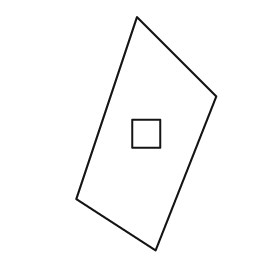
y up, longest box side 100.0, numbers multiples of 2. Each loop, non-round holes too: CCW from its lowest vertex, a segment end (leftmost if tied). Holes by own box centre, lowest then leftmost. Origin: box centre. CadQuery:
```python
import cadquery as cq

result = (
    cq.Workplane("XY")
    .moveTo(4.0, -50.0)
    .lineTo(30.0, 16.0)
    .lineTo(-4.0, 50.0)
    .lineTo(-30.0, -28.0)
    .close()
    .moveTo(-6.0, -6.0)
    .lineTo(6.0, -6.0)
    .lineTo(6.0, 6.0)
    .lineTo(-6.0, 6.0)
    .close()
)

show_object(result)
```